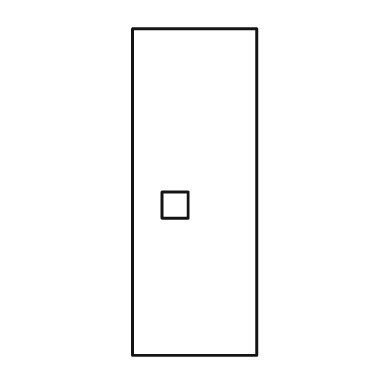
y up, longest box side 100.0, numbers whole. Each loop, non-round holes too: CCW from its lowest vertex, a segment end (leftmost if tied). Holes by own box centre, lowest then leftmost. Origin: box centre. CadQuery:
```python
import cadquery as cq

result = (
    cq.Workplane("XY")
    .moveTo(-19.0, -50.0)
    .lineTo(19.0, -50.0)
    .lineTo(19.0, 50.0)
    .lineTo(-19.0, 50.0)
    .close()
    .moveTo(-10.0, -8.0)
    .lineTo(-2.0, -8.0)
    .lineTo(-2.0, 0.0)
    .lineTo(-10.0, 0.0)
    .close()
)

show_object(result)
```